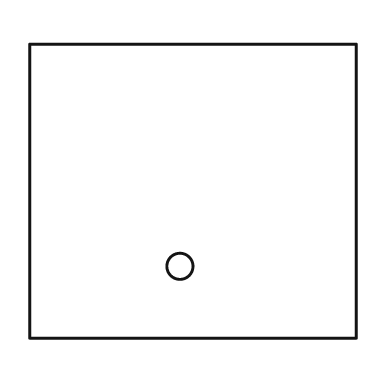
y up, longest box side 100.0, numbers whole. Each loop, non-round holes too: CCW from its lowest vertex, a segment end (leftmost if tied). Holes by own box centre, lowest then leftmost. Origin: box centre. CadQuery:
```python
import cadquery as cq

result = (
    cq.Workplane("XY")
    .moveTo(-50.0, -45.0)
    .lineTo(50.0, -45.0)
    .lineTo(50.0, 45.0)
    .lineTo(-50.0, 45.0)
    .close()
    .moveTo(-4.0, -23.0)
    .circle(4.0)
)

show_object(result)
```